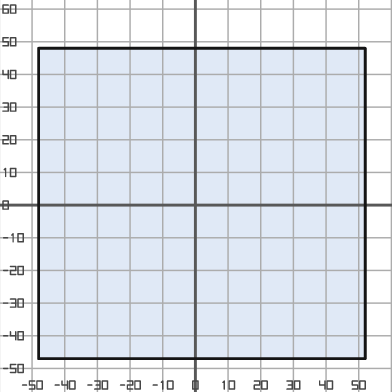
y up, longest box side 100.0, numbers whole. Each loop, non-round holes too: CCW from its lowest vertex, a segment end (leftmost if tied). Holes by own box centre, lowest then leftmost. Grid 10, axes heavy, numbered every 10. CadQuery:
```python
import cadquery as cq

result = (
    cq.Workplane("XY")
    .moveTo(-48.0, -47.0)
    .lineTo(52.0, -47.0)
    .lineTo(52.0, 48.0)
    .lineTo(-48.0, 48.0)
    .close()
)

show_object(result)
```